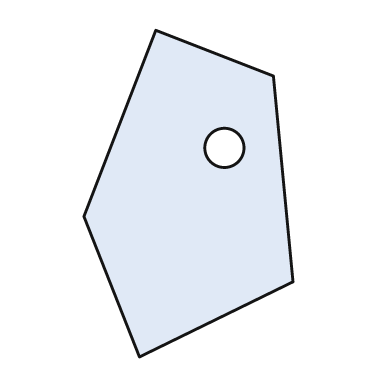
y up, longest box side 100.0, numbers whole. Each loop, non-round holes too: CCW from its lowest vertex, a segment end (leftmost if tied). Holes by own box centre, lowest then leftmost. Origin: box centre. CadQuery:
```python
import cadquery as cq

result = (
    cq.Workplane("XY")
    .moveTo(-15.0, -50.0)
    .lineTo(32.0, -27.0)
    .lineTo(26.0, 36.0)
    .lineTo(-10.0, 50.0)
    .lineTo(-32.0, -7.0)
    .close()
    .moveTo(11.0, 14.0)
    .circle(6.0)
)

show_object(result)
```